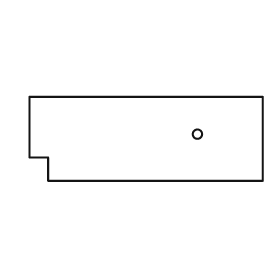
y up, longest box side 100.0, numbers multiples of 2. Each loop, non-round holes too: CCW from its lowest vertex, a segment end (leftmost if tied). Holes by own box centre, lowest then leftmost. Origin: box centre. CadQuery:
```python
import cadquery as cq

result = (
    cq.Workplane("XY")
    .moveTo(-42.0, -18.0)
    .lineTo(50.0, -18.0)
    .lineTo(50.0, 18.0)
    .lineTo(-50.0, 18.0)
    .lineTo(-50.0, -8.0)
    .lineTo(-42.0, -8.0)
    .close()
    .moveTo(22.0, 2.0)
    .circle(2.0)
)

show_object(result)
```